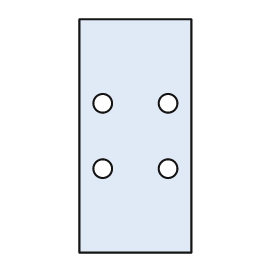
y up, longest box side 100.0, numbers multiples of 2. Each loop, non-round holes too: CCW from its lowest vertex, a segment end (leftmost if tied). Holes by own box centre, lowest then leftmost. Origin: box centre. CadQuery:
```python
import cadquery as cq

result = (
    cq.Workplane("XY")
    .moveTo(-24.0, -50.0)
    .lineTo(24.0, -50.0)
    .lineTo(24.0, 50.0)
    .lineTo(-24.0, 50.0)
    .close()
    .moveTo(-14.0, -14.0)
    .circle(4.0)
    .moveTo(14.0, -14.0)
    .circle(4.0)
    .moveTo(-14.0, 14.0)
    .circle(4.0)
    .moveTo(14.0, 14.0)
    .circle(4.0)
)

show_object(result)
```